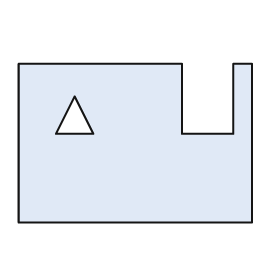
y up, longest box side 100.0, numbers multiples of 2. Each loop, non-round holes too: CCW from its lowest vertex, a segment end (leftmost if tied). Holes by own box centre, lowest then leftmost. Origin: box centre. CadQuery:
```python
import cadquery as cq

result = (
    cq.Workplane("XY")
    .moveTo(-50.0, -34.0)
    .lineTo(50.0, -34.0)
    .lineTo(50.0, 34.0)
    .lineTo(42.0, 34.0)
    .lineTo(42.0, 4.0)
    .lineTo(20.0, 4.0)
    .lineTo(20.0, 34.0)
    .lineTo(-50.0, 34.0)
    .close()
    .moveTo(-34.0, 4.0)
    .lineTo(-18.0, 4.0)
    .lineTo(-26.0, 20.0)
    .close()
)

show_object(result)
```